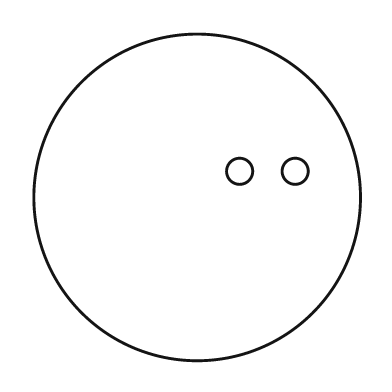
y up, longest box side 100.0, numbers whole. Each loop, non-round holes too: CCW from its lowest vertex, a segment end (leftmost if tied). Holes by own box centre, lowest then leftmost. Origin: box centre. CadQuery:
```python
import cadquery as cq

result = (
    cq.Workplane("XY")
    .moveTo(0.0, 0.0)
    .circle(50.0)
    .moveTo(13.0, 8.0)
    .circle(4.0)
    .moveTo(30.0, 8.0)
    .circle(4.0)
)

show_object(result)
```